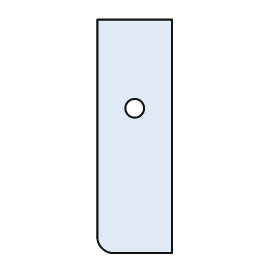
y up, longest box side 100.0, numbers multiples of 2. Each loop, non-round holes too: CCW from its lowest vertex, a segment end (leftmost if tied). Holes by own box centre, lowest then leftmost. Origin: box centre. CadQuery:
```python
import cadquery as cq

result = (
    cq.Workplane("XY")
    .moveTo(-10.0, -50.0)
    .lineTo(16.0, -50.0)
    .lineTo(16.0, 50.0)
    .lineTo(-16.0, 50.0)
    .lineTo(-16.0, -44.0)
    .threePointArc((-14.0, -48.0), (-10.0, -50.0))
    .close()
    .moveTo(0.0, 12.0)
    .circle(4.0)
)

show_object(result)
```